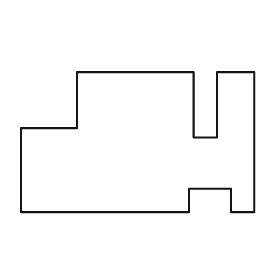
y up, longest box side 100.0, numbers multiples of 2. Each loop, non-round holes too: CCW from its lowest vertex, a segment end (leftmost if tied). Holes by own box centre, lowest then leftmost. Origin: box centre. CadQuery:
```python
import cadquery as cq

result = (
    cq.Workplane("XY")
    .moveTo(-50.0, -30.0)
    .lineTo(22.0, -30.0)
    .lineTo(22.0, -20.0)
    .lineTo(40.0, -20.0)
    .lineTo(40.0, -30.0)
    .lineTo(50.0, -30.0)
    .lineTo(50.0, 30.0)
    .lineTo(34.0, 30.0)
    .lineTo(34.0, 2.0)
    .lineTo(24.0, 2.0)
    .lineTo(24.0, 30.0)
    .lineTo(-26.0, 30.0)
    .lineTo(-26.0, 6.0)
    .lineTo(-50.0, 6.0)
    .close()
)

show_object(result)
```